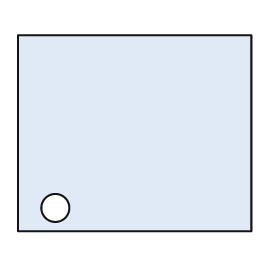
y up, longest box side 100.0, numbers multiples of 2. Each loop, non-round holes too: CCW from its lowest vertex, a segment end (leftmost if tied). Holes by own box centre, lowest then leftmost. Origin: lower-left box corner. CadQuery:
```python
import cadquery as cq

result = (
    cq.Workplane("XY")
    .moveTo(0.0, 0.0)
    .lineTo(100.0, 0.0)
    .lineTo(100.0, 84.0)
    .lineTo(0.0, 84.0)
    .close()
    .moveTo(16.0, 10.0)
    .circle(6.0)
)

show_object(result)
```